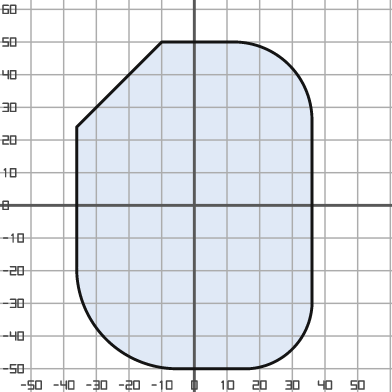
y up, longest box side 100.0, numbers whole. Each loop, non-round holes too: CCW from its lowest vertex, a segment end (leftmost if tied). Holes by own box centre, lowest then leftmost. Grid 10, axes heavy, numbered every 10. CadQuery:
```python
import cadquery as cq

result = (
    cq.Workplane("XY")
    .moveTo(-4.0, -50.0)
    .lineTo(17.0, -50.0)
    .threePointArc((30.0, -44.0), (36.0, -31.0))
    .lineTo(36.0, 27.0)
    .threePointArc((29.0, 43.0), (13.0, 50.0))
    .lineTo(-10.0, 50.0)
    .lineTo(-36.0, 24.0)
    .lineTo(-36.0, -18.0)
    .threePointArc((-27.0, -41.0), (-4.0, -50.0))
    .close()
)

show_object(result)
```